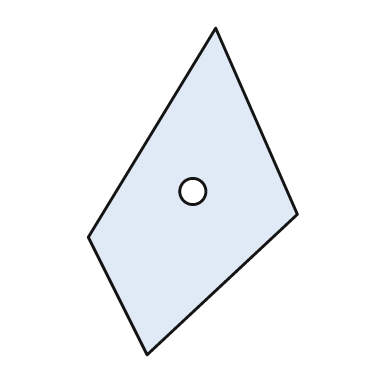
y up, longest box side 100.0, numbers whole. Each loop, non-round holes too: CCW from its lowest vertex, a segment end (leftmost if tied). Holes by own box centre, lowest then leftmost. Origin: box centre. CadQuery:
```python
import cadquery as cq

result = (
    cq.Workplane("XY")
    .moveTo(-14.0, -50.0)
    .lineTo(32.0, -7.0)
    .lineTo(7.0, 50.0)
    .lineTo(-32.0, -14.0)
    .close()
    .moveTo(0.0, 0.0)
    .circle(4.0)
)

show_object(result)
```